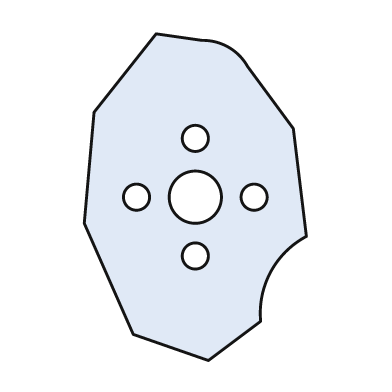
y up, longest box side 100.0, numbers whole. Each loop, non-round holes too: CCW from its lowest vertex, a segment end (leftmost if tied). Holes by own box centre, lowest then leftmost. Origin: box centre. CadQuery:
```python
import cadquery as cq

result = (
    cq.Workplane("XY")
    .moveTo(4.0, -50.0)
    .lineTo(20.0, -38.0)
    .threePointArc((23.0, -23.0), (34.0, -12.0))
    .lineTo(30.0, 21.0)
    .lineTo(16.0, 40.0)
    .threePointArc((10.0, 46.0), (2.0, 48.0))
    .lineTo(-12.0, 50.0)
    .lineTo(-31.0, 26.0)
    .lineTo(-34.0, -8.0)
    .lineTo(-19.0, -42.0)
    .close()
    .moveTo(0.0, -18.0)
    .circle(4.0)
    .moveTo(-18.0, 0.0)
    .circle(4.0)
    .moveTo(0.0, 0.0)
    .circle(8.0)
    .moveTo(18.0, 0.0)
    .circle(4.0)
    .moveTo(0.0, 18.0)
    .circle(4.0)
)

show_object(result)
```